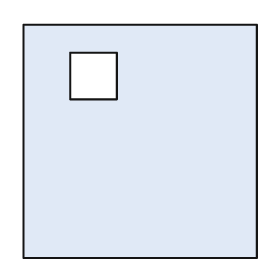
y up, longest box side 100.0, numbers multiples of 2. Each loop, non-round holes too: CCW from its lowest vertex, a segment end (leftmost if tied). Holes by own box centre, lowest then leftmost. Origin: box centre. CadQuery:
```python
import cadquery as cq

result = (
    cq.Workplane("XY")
    .moveTo(-50.0, -50.0)
    .lineTo(50.0, -50.0)
    .lineTo(50.0, 50.0)
    .lineTo(-50.0, 50.0)
    .close()
    .moveTo(-30.0, 18.0)
    .lineTo(-10.0, 18.0)
    .lineTo(-10.0, 38.0)
    .lineTo(-30.0, 38.0)
    .close()
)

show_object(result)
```